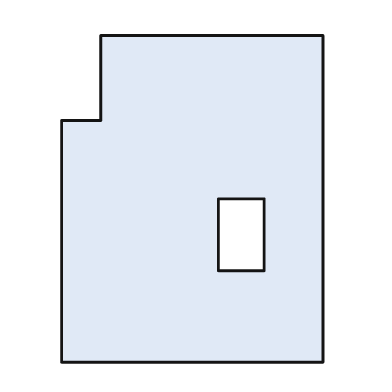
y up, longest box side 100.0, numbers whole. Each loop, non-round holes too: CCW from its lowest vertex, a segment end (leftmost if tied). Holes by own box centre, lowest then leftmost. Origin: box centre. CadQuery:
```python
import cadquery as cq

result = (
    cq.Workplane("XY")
    .moveTo(-40.0, -50.0)
    .lineTo(40.0, -50.0)
    .lineTo(40.0, 50.0)
    .lineTo(-28.0, 50.0)
    .lineTo(-28.0, 24.0)
    .lineTo(-40.0, 24.0)
    .close()
    .moveTo(8.0, -22.0)
    .lineTo(22.0, -22.0)
    .lineTo(22.0, 0.0)
    .lineTo(8.0, 0.0)
    .close()
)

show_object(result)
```